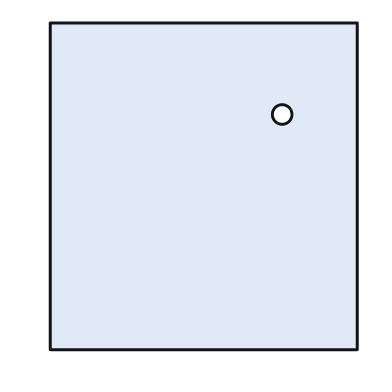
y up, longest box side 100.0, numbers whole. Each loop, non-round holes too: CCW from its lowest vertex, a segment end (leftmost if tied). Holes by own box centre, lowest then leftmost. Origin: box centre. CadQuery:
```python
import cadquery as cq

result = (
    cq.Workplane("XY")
    .moveTo(-47.0, -50.0)
    .lineTo(47.0, -50.0)
    .lineTo(47.0, 50.0)
    .lineTo(-47.0, 50.0)
    .close()
    .moveTo(24.0, 22.0)
    .circle(3.0)
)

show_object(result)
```